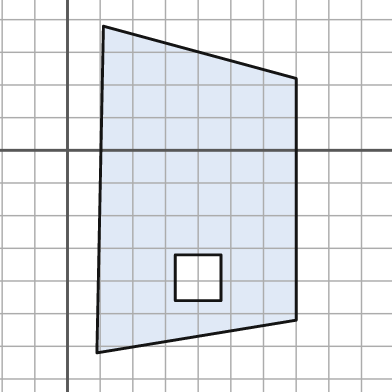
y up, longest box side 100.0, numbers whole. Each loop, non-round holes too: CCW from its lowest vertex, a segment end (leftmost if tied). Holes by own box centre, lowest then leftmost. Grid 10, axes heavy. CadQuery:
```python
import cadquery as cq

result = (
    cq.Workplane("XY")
    .moveTo(9.0, -62.0)
    .lineTo(70.0, -52.0)
    .lineTo(70.0, 22.0)
    .lineTo(11.0, 38.0)
    .close()
    .moveTo(33.0, -46.0)
    .lineTo(47.0, -46.0)
    .lineTo(47.0, -32.0)
    .lineTo(33.0, -32.0)
    .close()
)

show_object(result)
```